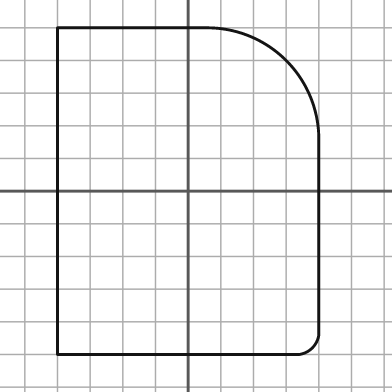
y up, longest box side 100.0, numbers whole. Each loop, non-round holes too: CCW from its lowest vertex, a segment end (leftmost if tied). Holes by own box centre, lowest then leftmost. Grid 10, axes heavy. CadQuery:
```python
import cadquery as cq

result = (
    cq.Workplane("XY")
    .moveTo(-40.0, -50.0)
    .lineTo(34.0, -50.0)
    .threePointArc((38.0, -48.0), (40.0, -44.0))
    .lineTo(40.0, 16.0)
    .threePointArc((30.0, 40.0), (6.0, 50.0))
    .lineTo(-40.0, 50.0)
    .close()
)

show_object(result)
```